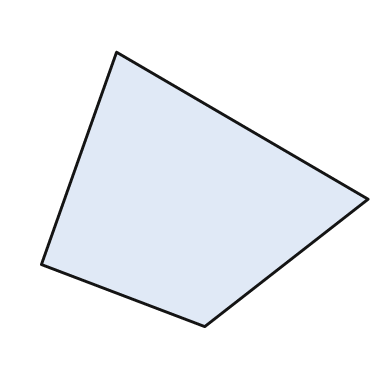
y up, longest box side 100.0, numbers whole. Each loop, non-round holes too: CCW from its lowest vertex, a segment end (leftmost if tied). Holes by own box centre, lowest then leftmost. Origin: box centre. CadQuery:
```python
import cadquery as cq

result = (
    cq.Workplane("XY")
    .moveTo(0.0, -42.0)
    .lineTo(50.0, -3.0)
    .lineTo(-27.0, 42.0)
    .lineTo(-50.0, -23.0)
    .close()
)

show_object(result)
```